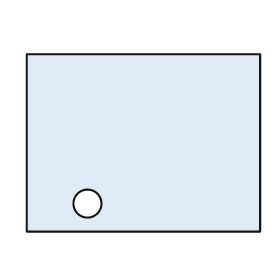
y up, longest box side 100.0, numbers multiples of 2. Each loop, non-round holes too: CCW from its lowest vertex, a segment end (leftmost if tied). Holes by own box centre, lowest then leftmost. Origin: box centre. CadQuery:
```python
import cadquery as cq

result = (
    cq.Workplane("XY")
    .moveTo(-50.0, -38.0)
    .lineTo(50.0, -38.0)
    .lineTo(50.0, 38.0)
    .lineTo(-50.0, 38.0)
    .close()
    .moveTo(-24.0, -26.0)
    .circle(6.0)
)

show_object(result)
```